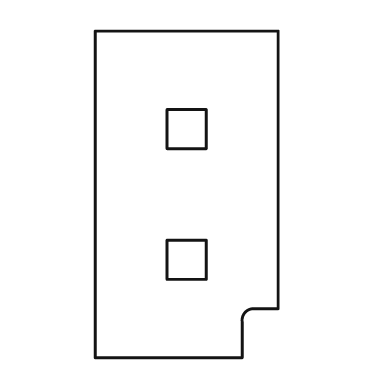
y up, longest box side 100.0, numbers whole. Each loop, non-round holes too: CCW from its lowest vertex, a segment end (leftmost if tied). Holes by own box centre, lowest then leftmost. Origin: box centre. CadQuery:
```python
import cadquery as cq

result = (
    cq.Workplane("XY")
    .moveTo(-28.0, -50.0)
    .lineTo(17.0, -50.0)
    .lineTo(17.0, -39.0)
    .threePointArc((18.0, -36.0), (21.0, -35.0))
    .lineTo(28.0, -35.0)
    .lineTo(28.0, 50.0)
    .lineTo(-28.0, 50.0)
    .close()
    .moveTo(-6.0, -26.0)
    .lineTo(6.0, -26.0)
    .lineTo(6.0, -14.0)
    .lineTo(-6.0, -14.0)
    .close()
    .moveTo(-6.0, 14.0)
    .lineTo(6.0, 14.0)
    .lineTo(6.0, 26.0)
    .lineTo(-6.0, 26.0)
    .close()
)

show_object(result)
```